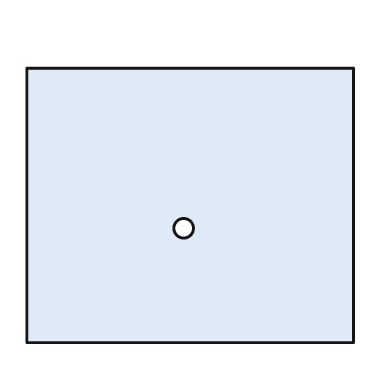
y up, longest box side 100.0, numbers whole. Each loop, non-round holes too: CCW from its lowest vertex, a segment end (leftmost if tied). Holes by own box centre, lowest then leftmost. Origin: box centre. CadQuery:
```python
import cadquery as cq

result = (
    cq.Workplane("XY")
    .moveTo(-50.0, -42.0)
    .lineTo(50.0, -42.0)
    .lineTo(50.0, 42.0)
    .lineTo(-50.0, 42.0)
    .close()
    .moveTo(-2.0, -7.0)
    .circle(3.0)
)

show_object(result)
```